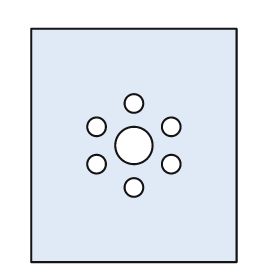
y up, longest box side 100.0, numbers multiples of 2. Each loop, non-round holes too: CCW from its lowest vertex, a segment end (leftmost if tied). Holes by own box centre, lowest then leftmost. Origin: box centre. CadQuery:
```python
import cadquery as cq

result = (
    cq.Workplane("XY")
    .moveTo(-44.0, -50.0)
    .lineTo(44.0, -50.0)
    .lineTo(44.0, 50.0)
    .lineTo(-44.0, 50.0)
    .close()
    .moveTo(0.0, -18.0)
    .circle(4.0)
    .moveTo(-16.0, -8.0)
    .circle(4.0)
    .moveTo(16.0, -8.0)
    .circle(4.0)
    .moveTo(0.0, 0.0)
    .circle(8.0)
    .moveTo(-16.0, 8.0)
    .circle(4.0)
    .moveTo(16.0, 8.0)
    .circle(4.0)
    .moveTo(0.0, 18.0)
    .circle(4.0)
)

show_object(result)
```